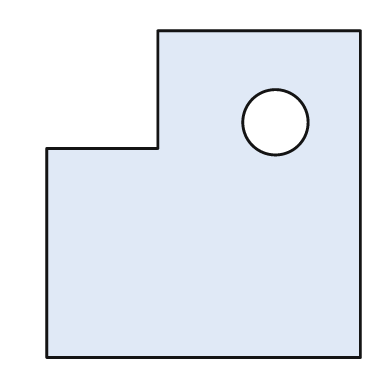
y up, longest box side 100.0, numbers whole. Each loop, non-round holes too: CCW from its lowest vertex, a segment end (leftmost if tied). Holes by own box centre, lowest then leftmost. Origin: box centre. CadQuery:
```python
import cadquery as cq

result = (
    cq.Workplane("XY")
    .moveTo(-48.0, -50.0)
    .lineTo(48.0, -50.0)
    .lineTo(48.0, 50.0)
    .lineTo(-14.0, 50.0)
    .lineTo(-14.0, 14.0)
    .lineTo(-48.0, 14.0)
    .close()
    .moveTo(22.0, 22.0)
    .circle(10.0)
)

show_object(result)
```